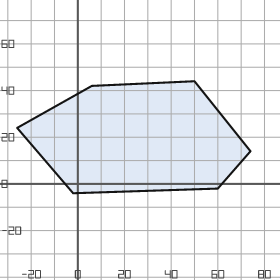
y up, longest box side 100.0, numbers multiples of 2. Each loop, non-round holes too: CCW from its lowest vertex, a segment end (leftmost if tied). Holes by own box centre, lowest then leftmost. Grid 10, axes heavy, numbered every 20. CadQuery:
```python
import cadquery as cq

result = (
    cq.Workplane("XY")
    .moveTo(-2.0, -4.0)
    .lineTo(60.0, -2.0)
    .lineTo(74.0, 14.0)
    .lineTo(50.0, 44.0)
    .lineTo(6.0, 42.0)
    .lineTo(-26.0, 24.0)
    .close()
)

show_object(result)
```